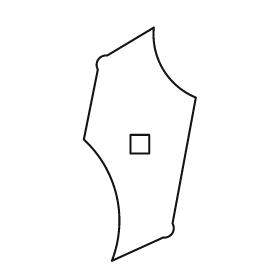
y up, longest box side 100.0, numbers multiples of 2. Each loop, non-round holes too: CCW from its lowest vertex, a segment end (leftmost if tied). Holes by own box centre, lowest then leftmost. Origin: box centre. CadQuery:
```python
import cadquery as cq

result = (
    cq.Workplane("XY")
    .moveTo(-12.0, -50.0)
    .lineTo(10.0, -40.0)
    .threePointArc((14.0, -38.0), (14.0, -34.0))
    .lineTo(24.0, 20.0)
    .threePointArc((10.0, 32.0), (6.0, 50.0))
    .lineTo(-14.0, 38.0)
    .threePointArc((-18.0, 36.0), (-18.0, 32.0))
    .lineTo(-24.0, 2.0)
    .threePointArc((-10.0, -22.0), (-12.0, -50.0))
    .close()
    .moveTo(-4.0, -4.0)
    .lineTo(4.0, -4.0)
    .lineTo(4.0, 4.0)
    .lineTo(-4.0, 4.0)
    .close()
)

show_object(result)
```